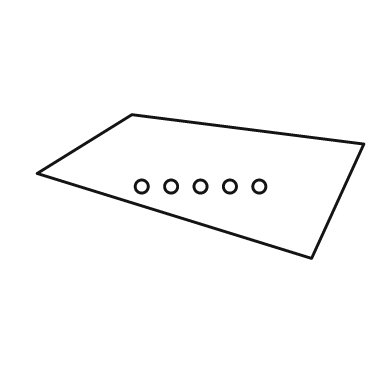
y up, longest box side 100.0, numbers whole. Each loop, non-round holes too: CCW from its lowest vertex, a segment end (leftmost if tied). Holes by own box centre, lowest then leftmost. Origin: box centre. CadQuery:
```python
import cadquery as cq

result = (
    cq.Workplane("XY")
    .moveTo(34.0, -22.0)
    .lineTo(50.0, 13.0)
    .lineTo(-21.0, 22.0)
    .lineTo(-50.0, 4.0)
    .close()
    .moveTo(-18.0, 0.0)
    .circle(2.0)
    .moveTo(-9.0, 0.0)
    .circle(2.0)
    .moveTo(0.0, 0.0)
    .circle(2.0)
    .moveTo(9.0, 0.0)
    .circle(2.0)
    .moveTo(18.0, 0.0)
    .circle(2.0)
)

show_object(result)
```